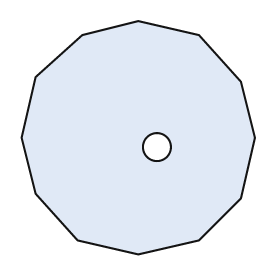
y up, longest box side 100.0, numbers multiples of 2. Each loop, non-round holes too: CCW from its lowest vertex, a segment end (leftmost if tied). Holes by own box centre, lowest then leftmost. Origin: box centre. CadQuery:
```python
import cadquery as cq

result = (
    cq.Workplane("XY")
    .moveTo(0.0, -50.0)
    .lineTo(26.0, -44.0)
    .lineTo(44.0, -26.0)
    .lineTo(50.0, 0.0)
    .lineTo(44.0, 24.0)
    .lineTo(26.0, 44.0)
    .lineTo(0.0, 50.0)
    .lineTo(-24.0, 44.0)
    .lineTo(-44.0, 26.0)
    .lineTo(-50.0, 0.0)
    .lineTo(-44.0, -24.0)
    .lineTo(-26.0, -44.0)
    .close()
    .moveTo(8.0, -4.0)
    .circle(6.0)
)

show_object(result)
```